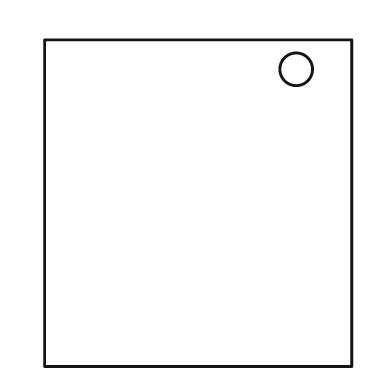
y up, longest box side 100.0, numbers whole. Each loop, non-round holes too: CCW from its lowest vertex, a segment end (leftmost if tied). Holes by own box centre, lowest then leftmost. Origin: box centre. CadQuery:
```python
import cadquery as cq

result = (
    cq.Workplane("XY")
    .moveTo(-47.0, -50.0)
    .lineTo(47.0, -50.0)
    .lineTo(47.0, 50.0)
    .lineTo(-47.0, 50.0)
    .close()
    .moveTo(30.0, 41.0)
    .circle(5.0)
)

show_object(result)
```